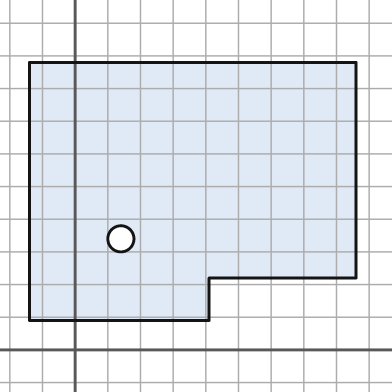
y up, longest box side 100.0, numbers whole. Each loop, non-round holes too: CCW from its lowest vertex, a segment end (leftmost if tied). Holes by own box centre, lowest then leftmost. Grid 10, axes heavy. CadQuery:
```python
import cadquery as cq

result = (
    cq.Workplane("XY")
    .moveTo(-14.0, 9.0)
    .lineTo(41.0, 9.0)
    .lineTo(41.0, 22.0)
    .lineTo(86.0, 22.0)
    .lineTo(86.0, 88.0)
    .lineTo(-14.0, 88.0)
    .close()
    .moveTo(14.0, 34.0)
    .circle(4.0)
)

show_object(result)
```